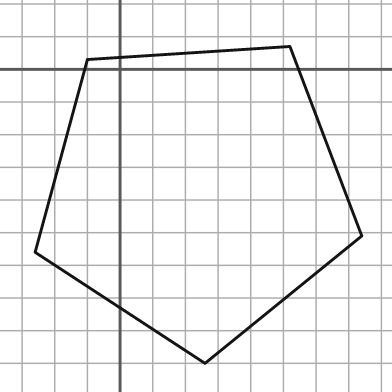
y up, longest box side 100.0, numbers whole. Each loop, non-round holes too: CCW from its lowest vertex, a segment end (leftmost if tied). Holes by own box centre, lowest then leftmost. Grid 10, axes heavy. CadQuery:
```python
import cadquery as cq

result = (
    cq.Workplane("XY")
    .moveTo(26.0, -90.0)
    .lineTo(74.0, -51.0)
    .lineTo(52.0, 7.0)
    .lineTo(-10.0, 3.0)
    .lineTo(-26.0, -56.0)
    .close()
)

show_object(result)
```